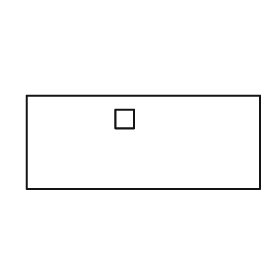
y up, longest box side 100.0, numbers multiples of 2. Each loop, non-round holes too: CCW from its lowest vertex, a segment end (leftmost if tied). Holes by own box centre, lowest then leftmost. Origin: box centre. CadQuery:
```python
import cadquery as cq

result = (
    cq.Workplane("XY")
    .moveTo(-50.0, -20.0)
    .lineTo(50.0, -20.0)
    .lineTo(50.0, 20.0)
    .lineTo(-50.0, 20.0)
    .close()
    .moveTo(-12.0, 6.0)
    .lineTo(-4.0, 6.0)
    .lineTo(-4.0, 14.0)
    .lineTo(-12.0, 14.0)
    .close()
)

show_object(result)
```